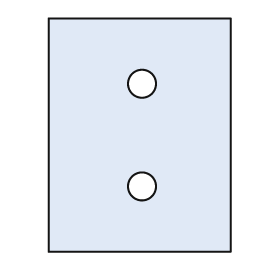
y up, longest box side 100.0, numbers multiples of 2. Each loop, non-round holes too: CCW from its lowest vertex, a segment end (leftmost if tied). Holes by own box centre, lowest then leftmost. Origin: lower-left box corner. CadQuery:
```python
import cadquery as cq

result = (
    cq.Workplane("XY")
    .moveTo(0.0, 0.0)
    .lineTo(78.0, 0.0)
    .lineTo(78.0, 100.0)
    .lineTo(0.0, 100.0)
    .close()
    .moveTo(40.0, 28.0)
    .circle(6.0)
    .moveTo(40.0, 72.0)
    .circle(6.0)
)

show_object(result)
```